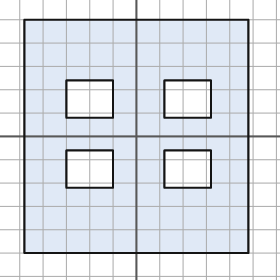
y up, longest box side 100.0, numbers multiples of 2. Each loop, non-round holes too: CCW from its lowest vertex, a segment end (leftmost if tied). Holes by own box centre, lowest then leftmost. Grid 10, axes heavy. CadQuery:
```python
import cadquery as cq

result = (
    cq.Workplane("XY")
    .moveTo(-48.0, -50.0)
    .lineTo(48.0, -50.0)
    .lineTo(48.0, 50.0)
    .lineTo(-48.0, 50.0)
    .close()
    .moveTo(-30.0, -22.0)
    .lineTo(-10.0, -22.0)
    .lineTo(-10.0, -6.0)
    .lineTo(-30.0, -6.0)
    .close()
    .moveTo(12.0, -22.0)
    .lineTo(32.0, -22.0)
    .lineTo(32.0, -6.0)
    .lineTo(12.0, -6.0)
    .close()
    .moveTo(-30.0, 8.0)
    .lineTo(-10.0, 8.0)
    .lineTo(-10.0, 24.0)
    .lineTo(-30.0, 24.0)
    .close()
    .moveTo(12.0, 8.0)
    .lineTo(32.0, 8.0)
    .lineTo(32.0, 24.0)
    .lineTo(12.0, 24.0)
    .close()
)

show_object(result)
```